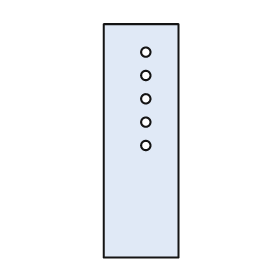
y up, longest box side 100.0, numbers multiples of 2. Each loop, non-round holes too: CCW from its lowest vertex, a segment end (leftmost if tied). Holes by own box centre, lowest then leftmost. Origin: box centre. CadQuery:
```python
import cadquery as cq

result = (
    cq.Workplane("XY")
    .moveTo(-16.0, -50.0)
    .lineTo(16.0, -50.0)
    .lineTo(16.0, 50.0)
    .lineTo(-16.0, 50.0)
    .close()
    .moveTo(2.0, -2.0)
    .circle(2.0)
    .moveTo(2.0, 8.0)
    .circle(2.0)
    .moveTo(2.0, 18.0)
    .circle(2.0)
    .moveTo(2.0, 28.0)
    .circle(2.0)
    .moveTo(2.0, 38.0)
    .circle(2.0)
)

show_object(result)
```